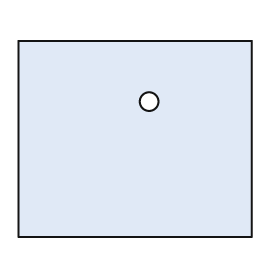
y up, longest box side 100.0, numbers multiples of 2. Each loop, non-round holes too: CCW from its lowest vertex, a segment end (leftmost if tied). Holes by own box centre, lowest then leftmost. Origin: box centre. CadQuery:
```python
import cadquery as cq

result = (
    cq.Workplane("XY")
    .moveTo(-50.0, -42.0)
    .lineTo(50.0, -42.0)
    .lineTo(50.0, 42.0)
    .lineTo(-50.0, 42.0)
    .close()
    .moveTo(6.0, 16.0)
    .circle(4.0)
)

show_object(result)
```